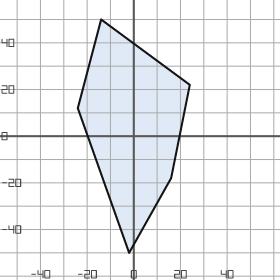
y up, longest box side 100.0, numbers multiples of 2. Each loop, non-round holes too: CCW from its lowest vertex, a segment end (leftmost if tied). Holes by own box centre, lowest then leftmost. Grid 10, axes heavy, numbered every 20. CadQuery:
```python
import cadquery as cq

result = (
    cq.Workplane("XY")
    .moveTo(-2.0, -50.0)
    .lineTo(16.0, -18.0)
    .lineTo(24.0, 22.0)
    .lineTo(-14.0, 50.0)
    .lineTo(-24.0, 12.0)
    .close()
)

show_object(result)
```